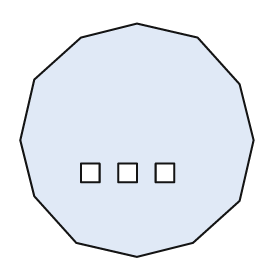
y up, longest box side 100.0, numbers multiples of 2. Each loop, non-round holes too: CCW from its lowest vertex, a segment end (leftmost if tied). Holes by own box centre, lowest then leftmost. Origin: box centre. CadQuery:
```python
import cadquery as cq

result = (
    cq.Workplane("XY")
    .moveTo(0.0, -50.0)
    .lineTo(24.0, -44.0)
    .lineTo(44.0, -26.0)
    .lineTo(50.0, 0.0)
    .lineTo(44.0, 24.0)
    .lineTo(26.0, 44.0)
    .lineTo(0.0, 50.0)
    .lineTo(-24.0, 44.0)
    .lineTo(-44.0, 26.0)
    .lineTo(-50.0, 0.0)
    .lineTo(-44.0, -24.0)
    .lineTo(-26.0, -44.0)
    .close()
    .moveTo(-24.0, -18.0)
    .lineTo(-16.0, -18.0)
    .lineTo(-16.0, -10.0)
    .lineTo(-24.0, -10.0)
    .close()
    .moveTo(-8.0, -18.0)
    .lineTo(0.0, -18.0)
    .lineTo(0.0, -10.0)
    .lineTo(-8.0, -10.0)
    .close()
    .moveTo(8.0, -18.0)
    .lineTo(16.0, -18.0)
    .lineTo(16.0, -10.0)
    .lineTo(8.0, -10.0)
    .close()
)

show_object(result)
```